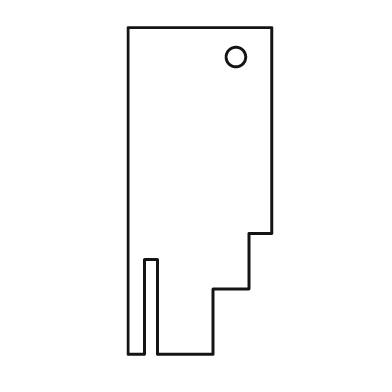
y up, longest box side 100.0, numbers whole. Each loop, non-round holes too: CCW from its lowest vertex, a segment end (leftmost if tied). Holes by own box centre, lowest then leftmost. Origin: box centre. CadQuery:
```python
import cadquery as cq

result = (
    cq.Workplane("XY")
    .moveTo(-22.0, -50.0)
    .lineTo(-17.0, -50.0)
    .lineTo(-17.0, -21.0)
    .lineTo(-13.0, -21.0)
    .lineTo(-13.0, -50.0)
    .lineTo(4.0, -50.0)
    .lineTo(4.0, -30.0)
    .lineTo(15.0, -30.0)
    .lineTo(15.0, -13.0)
    .lineTo(22.0, -13.0)
    .lineTo(22.0, 50.0)
    .lineTo(-22.0, 50.0)
    .close()
    .moveTo(11.0, 41.0)
    .circle(3.0)
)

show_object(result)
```